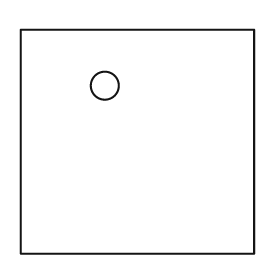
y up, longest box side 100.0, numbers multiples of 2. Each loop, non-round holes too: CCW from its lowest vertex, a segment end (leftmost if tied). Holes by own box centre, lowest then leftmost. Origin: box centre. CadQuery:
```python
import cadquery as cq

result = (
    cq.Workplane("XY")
    .moveTo(-50.0, -48.0)
    .lineTo(50.0, -48.0)
    .lineTo(50.0, 48.0)
    .lineTo(-50.0, 48.0)
    .close()
    .moveTo(-14.0, 24.0)
    .circle(6.0)
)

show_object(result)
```